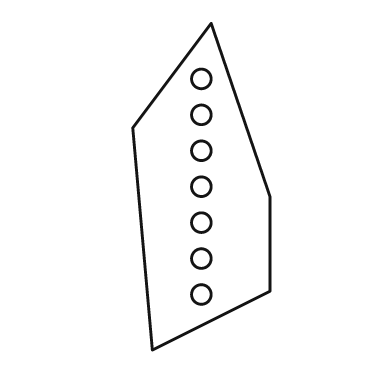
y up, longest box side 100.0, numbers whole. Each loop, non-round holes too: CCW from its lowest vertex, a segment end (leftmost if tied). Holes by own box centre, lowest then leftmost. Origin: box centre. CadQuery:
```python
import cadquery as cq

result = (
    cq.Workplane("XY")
    .moveTo(-15.0, -50.0)
    .lineTo(21.0, -32.0)
    .lineTo(21.0, -3.0)
    .lineTo(3.0, 50.0)
    .lineTo(-21.0, 18.0)
    .close()
    .moveTo(0.0, -33.0)
    .circle(3.0)
    .moveTo(0.0, -22.0)
    .circle(3.0)
    .moveTo(0.0, -11.0)
    .circle(3.0)
    .moveTo(0.0, 0.0)
    .circle(3.0)
    .moveTo(0.0, 11.0)
    .circle(3.0)
    .moveTo(0.0, 22.0)
    .circle(3.0)
    .moveTo(0.0, 33.0)
    .circle(3.0)
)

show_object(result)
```